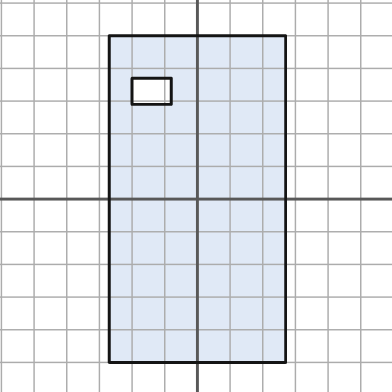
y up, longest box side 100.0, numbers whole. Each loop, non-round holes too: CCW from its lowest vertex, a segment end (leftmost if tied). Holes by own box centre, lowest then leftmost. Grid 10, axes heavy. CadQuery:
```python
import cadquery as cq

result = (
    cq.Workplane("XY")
    .moveTo(-27.0, -50.0)
    .lineTo(27.0, -50.0)
    .lineTo(27.0, 50.0)
    .lineTo(-27.0, 50.0)
    .close()
    .moveTo(-20.0, 29.0)
    .lineTo(-8.0, 29.0)
    .lineTo(-8.0, 37.0)
    .lineTo(-20.0, 37.0)
    .close()
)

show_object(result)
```